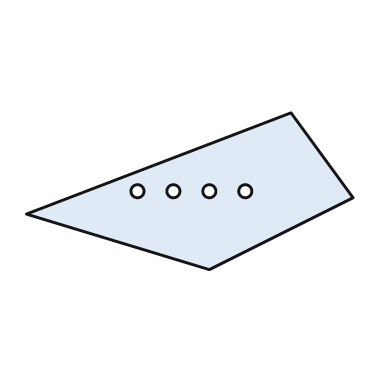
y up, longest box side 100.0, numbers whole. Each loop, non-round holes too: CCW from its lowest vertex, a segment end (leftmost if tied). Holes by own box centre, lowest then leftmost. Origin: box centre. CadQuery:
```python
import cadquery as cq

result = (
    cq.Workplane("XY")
    .moveTo(6.0, -24.0)
    .lineTo(50.0, -2.0)
    .lineTo(31.0, 24.0)
    .lineTo(-50.0, -7.0)
    .close()
    .moveTo(-16.0, 0.0)
    .circle(2.0)
    .moveTo(-5.0, 0.0)
    .circle(2.0)
    .moveTo(6.0, 0.0)
    .circle(2.0)
    .moveTo(17.0, 0.0)
    .circle(2.0)
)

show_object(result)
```